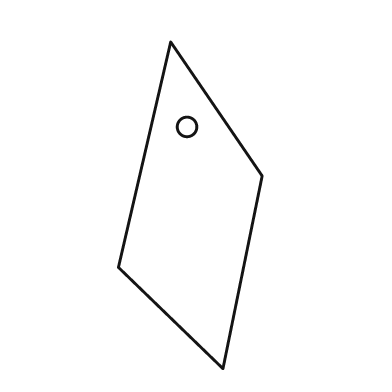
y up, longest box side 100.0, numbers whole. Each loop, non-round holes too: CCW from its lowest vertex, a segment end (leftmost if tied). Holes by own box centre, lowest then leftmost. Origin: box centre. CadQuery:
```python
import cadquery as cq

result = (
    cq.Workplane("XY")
    .moveTo(10.0, -50.0)
    .lineTo(22.0, 9.0)
    .lineTo(-6.0, 50.0)
    .lineTo(-22.0, -19.0)
    .close()
    .moveTo(-1.0, 24.0)
    .circle(3.0)
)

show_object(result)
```